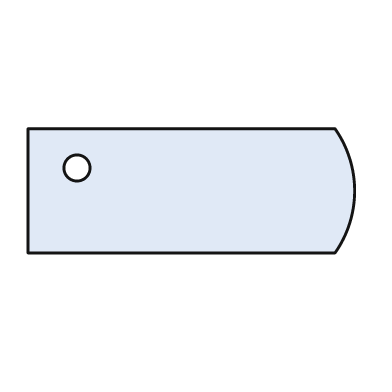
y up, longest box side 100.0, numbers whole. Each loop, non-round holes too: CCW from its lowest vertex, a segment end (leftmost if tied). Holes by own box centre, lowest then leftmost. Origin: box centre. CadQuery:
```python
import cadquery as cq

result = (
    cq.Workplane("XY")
    .moveTo(-50.0, -19.0)
    .lineTo(44.0, -19.0)
    .threePointArc((50.0, 0.0), (44.0, 19.0))
    .lineTo(-50.0, 19.0)
    .close()
    .moveTo(-35.0, 7.0)
    .circle(4.0)
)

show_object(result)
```